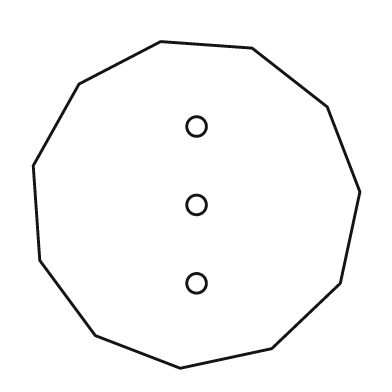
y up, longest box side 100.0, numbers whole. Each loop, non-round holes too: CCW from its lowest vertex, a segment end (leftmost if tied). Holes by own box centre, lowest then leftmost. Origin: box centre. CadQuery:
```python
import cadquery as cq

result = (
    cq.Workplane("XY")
    .moveTo(-5.0, -50.0)
    .lineTo(23.0, -44.0)
    .lineTo(44.0, -24.0)
    .lineTo(50.0, 4.0)
    .lineTo(40.0, 30.0)
    .lineTo(17.0, 48.0)
    .lineTo(-11.0, 50.0)
    .lineTo(-36.0, 37.0)
    .lineTo(-50.0, 12.0)
    .lineTo(-48.0, -17.0)
    .lineTo(-31.0, -40.0)
    .close()
    .moveTo(0.0, -24.0)
    .circle(3.0)
    .moveTo(0.0, 0.0)
    .circle(3.0)
    .moveTo(0.0, 24.0)
    .circle(3.0)
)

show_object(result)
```